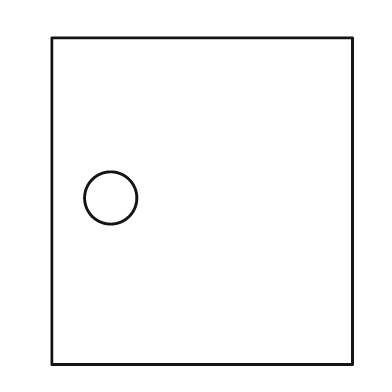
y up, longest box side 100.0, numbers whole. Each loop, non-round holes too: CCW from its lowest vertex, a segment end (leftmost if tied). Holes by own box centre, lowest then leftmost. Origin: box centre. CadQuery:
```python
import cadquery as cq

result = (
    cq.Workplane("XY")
    .moveTo(-46.0, -50.0)
    .lineTo(46.0, -50.0)
    .lineTo(46.0, 50.0)
    .lineTo(-46.0, 50.0)
    .close()
    .moveTo(-28.0, 1.0)
    .circle(8.0)
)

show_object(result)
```